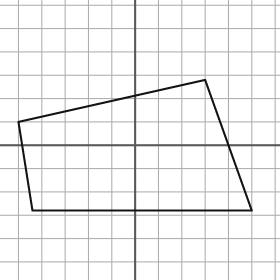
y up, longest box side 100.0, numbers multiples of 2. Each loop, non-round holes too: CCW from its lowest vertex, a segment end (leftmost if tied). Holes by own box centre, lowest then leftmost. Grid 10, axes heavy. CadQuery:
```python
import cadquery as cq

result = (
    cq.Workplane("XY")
    .moveTo(-44.0, -28.0)
    .lineTo(50.0, -28.0)
    .lineTo(30.0, 28.0)
    .lineTo(-50.0, 10.0)
    .close()
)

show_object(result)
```